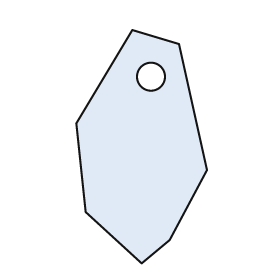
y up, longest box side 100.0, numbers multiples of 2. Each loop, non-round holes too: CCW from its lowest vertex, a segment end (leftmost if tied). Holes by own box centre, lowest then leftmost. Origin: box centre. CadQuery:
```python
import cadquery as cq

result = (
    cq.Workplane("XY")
    .moveTo(0.0, -50.0)
    .lineTo(12.0, -40.0)
    .lineTo(28.0, -10.0)
    .lineTo(16.0, 44.0)
    .lineTo(-4.0, 50.0)
    .lineTo(-28.0, 10.0)
    .lineTo(-24.0, -28.0)
    .close()
    .moveTo(4.0, 30.0)
    .circle(6.0)
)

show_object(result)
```